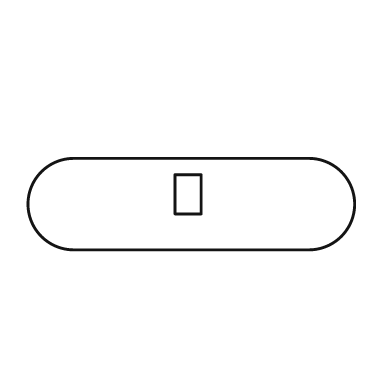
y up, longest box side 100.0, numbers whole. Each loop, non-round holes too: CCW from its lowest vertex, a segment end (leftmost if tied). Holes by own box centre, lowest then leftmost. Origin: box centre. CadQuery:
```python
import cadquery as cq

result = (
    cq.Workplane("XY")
    .moveTo(-36.0, -14.0)
    .lineTo(36.0, -14.0)
    .threePointArc((50.0, 0.0), (36.0, 14.0))
    .lineTo(-36.0, 14.0)
    .threePointArc((-50.0, 0.0), (-36.0, -14.0))
    .close()
    .moveTo(-5.0, -3.0)
    .lineTo(3.0, -3.0)
    .lineTo(3.0, 9.0)
    .lineTo(-5.0, 9.0)
    .close()
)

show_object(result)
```